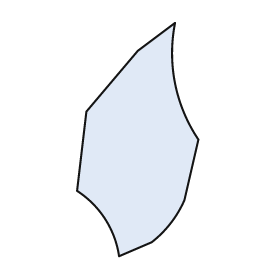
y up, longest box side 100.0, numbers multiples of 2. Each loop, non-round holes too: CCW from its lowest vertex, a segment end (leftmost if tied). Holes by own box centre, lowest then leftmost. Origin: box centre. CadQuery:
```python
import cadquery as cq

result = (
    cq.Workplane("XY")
    .moveTo(-8.0, -50.0)
    .lineTo(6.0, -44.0)
    .threePointArc((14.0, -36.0), (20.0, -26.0))
    .lineTo(26.0, 0.0)
    .threePointArc((16.0, 24.0), (16.0, 50.0))
    .lineTo(0.0, 38.0)
    .lineTo(-22.0, 12.0)
    .lineTo(-26.0, -22.0)
    .threePointArc((-14.0, -34.0), (-8.0, -50.0))
    .close()
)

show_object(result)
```